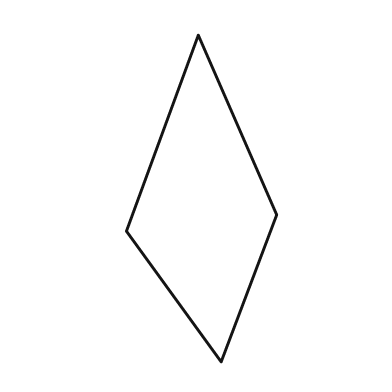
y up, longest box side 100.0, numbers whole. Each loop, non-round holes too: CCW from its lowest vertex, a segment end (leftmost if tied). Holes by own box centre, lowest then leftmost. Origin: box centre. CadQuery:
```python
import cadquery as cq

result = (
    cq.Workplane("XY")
    .moveTo(6.0, -50.0)
    .lineTo(23.0, -5.0)
    .lineTo(-1.0, 50.0)
    .lineTo(-23.0, -10.0)
    .close()
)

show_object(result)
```